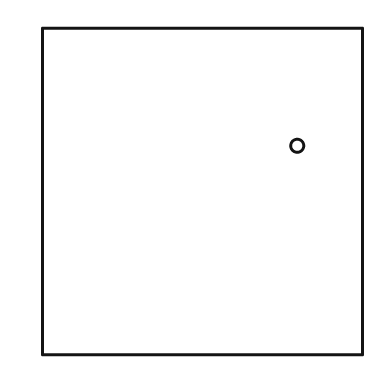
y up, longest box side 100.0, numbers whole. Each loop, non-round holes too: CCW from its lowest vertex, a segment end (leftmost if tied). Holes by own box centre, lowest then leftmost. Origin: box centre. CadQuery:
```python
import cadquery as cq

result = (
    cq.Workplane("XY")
    .moveTo(-49.0, -50.0)
    .lineTo(49.0, -50.0)
    .lineTo(49.0, 50.0)
    .lineTo(-49.0, 50.0)
    .close()
    .moveTo(29.0, 14.0)
    .circle(2.0)
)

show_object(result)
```